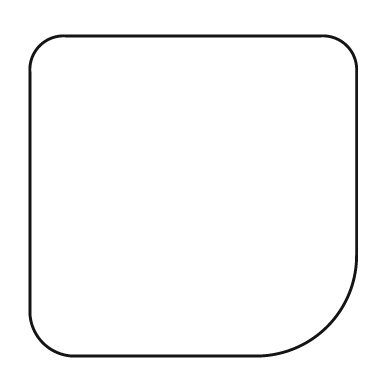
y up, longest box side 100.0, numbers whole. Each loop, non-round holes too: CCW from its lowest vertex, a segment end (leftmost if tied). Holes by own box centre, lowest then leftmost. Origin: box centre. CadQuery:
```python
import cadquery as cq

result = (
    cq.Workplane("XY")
    .moveTo(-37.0, -49.0)
    .lineTo(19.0, -49.0)
    .threePointArc((41.0, -40.0), (50.0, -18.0))
    .lineTo(50.0, 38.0)
    .threePointArc((47.0, 46.0), (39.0, 49.0))
    .lineTo(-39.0, 49.0)
    .threePointArc((-47.0, 46.0), (-50.0, 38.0))
    .lineTo(-50.0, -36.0)
    .threePointArc((-46.0, -45.0), (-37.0, -49.0))
    .close()
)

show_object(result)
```